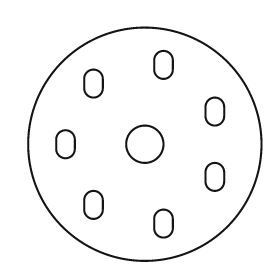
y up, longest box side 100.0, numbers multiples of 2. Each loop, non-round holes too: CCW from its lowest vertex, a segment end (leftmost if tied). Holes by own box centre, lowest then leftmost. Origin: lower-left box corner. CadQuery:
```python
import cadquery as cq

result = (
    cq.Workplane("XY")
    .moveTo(50.0, 50.0)
    .circle(50.0)
    .moveTo(54.0, 14.0)
    .threePointArc((58.0, 10.0), (62.0, 14.0))
    .lineTo(62.0, 18.0)
    .threePointArc((58.0, 22.0), (54.0, 18.0))
    .close()
    .moveTo(24.0, 22.0)
    .threePointArc((28.0, 18.0), (32.0, 22.0))
    .lineTo(32.0, 26.0)
    .threePointArc((28.0, 30.0), (24.0, 26.0))
    .close()
    .moveTo(76.0, 34.0)
    .threePointArc((80.0, 30.0), (84.0, 34.0))
    .lineTo(84.0, 38.0)
    .threePointArc((80.0, 42.0), (76.0, 38.0))
    .close()
    .moveTo(12.0, 48.0)
    .threePointArc((16.0, 44.0), (20.0, 48.0))
    .lineTo(20.0, 52.0)
    .threePointArc((16.0, 56.0), (12.0, 52.0))
    .close()
    .moveTo(50.0, 50.0)
    .circle(8.0)
    .moveTo(76.0, 62.0)
    .threePointArc((80.0, 58.0), (84.0, 62.0))
    .lineTo(84.0, 66.0)
    .threePointArc((80.0, 70.0), (76.0, 66.0))
    .close()
    .moveTo(24.0, 74.0)
    .threePointArc((28.0, 70.0), (32.0, 74.0))
    .lineTo(32.0, 78.0)
    .threePointArc((28.0, 82.0), (24.0, 78.0))
    .close()
    .moveTo(54.0, 82.0)
    .threePointArc((58.0, 78.0), (62.0, 82.0))
    .lineTo(62.0, 86.0)
    .threePointArc((58.0, 90.0), (54.0, 86.0))
    .close()
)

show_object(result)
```